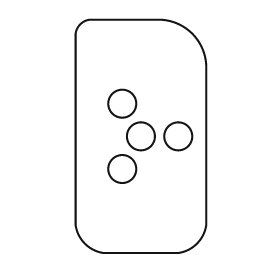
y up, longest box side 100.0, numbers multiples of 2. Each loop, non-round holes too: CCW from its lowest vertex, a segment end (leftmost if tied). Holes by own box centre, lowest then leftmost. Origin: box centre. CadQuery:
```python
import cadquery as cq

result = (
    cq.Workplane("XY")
    .moveTo(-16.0, -50.0)
    .lineTo(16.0, -50.0)
    .threePointArc((24.0, -46.0), (28.0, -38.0))
    .lineTo(28.0, 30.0)
    .threePointArc((22.0, 44.0), (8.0, 50.0))
    .lineTo(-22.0, 50.0)
    .threePointArc((-26.0, 48.0), (-28.0, 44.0))
    .lineTo(-28.0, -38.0)
    .threePointArc((-24.0, -46.0), (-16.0, -50.0))
    .close()
    .moveTo(-8.0, -14.0)
    .circle(6.0)
    .moveTo(0.0, 0.0)
    .circle(6.0)
    .moveTo(16.0, 0.0)
    .circle(6.0)
    .moveTo(-8.0, 14.0)
    .circle(6.0)
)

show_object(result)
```